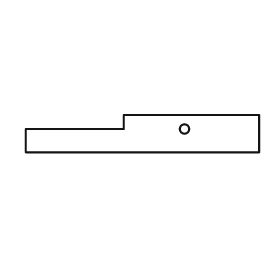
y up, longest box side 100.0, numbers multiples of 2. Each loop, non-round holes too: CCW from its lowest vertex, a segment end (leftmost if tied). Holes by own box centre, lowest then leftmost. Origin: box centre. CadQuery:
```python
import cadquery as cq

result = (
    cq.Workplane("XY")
    .moveTo(-50.0, -8.0)
    .lineTo(50.0, -8.0)
    .lineTo(50.0, 8.0)
    .lineTo(-8.0, 8.0)
    .lineTo(-8.0, 2.0)
    .lineTo(-50.0, 2.0)
    .close()
    .moveTo(18.0, 2.0)
    .circle(2.0)
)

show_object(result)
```